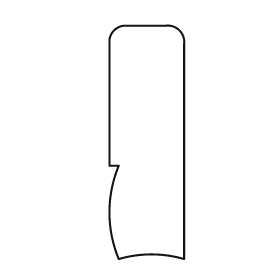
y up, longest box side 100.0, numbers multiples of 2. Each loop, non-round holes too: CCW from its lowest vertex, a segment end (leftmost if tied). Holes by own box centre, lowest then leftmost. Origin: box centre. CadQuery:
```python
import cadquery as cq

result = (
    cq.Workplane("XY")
    .moveTo(-12.0, -50.0)
    .threePointArc((2.0, -48.0), (16.0, -50.0))
    .lineTo(16.0, 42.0)
    .threePointArc((14.0, 48.0), (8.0, 50.0))
    .lineTo(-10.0, 50.0)
    .threePointArc((-14.0, 48.0), (-16.0, 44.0))
    .lineTo(-16.0, -10.0)
    .lineTo(-12.0, -10.0)
    .threePointArc((-16.0, -30.0), (-12.0, -50.0))
    .close()
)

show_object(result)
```